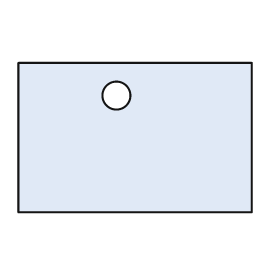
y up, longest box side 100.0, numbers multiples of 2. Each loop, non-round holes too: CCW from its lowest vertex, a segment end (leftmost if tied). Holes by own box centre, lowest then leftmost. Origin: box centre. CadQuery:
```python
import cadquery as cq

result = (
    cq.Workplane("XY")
    .moveTo(-50.0, -32.0)
    .lineTo(50.0, -32.0)
    .lineTo(50.0, 32.0)
    .lineTo(-50.0, 32.0)
    .close()
    .moveTo(-8.0, 18.0)
    .circle(6.0)
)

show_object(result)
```